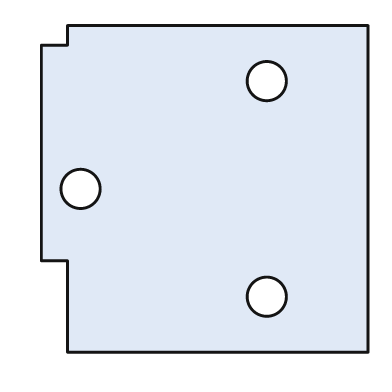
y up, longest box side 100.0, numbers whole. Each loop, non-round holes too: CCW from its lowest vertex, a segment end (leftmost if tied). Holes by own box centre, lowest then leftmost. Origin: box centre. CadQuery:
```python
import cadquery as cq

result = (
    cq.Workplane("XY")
    .moveTo(-42.0, -50.0)
    .lineTo(50.0, -50.0)
    .lineTo(50.0, 50.0)
    .lineTo(-42.0, 50.0)
    .lineTo(-42.0, 44.0)
    .lineTo(-50.0, 44.0)
    .lineTo(-50.0, -22.0)
    .lineTo(-42.0, -22.0)
    .close()
    .moveTo(19.0, -33.0)
    .circle(6.0)
    .moveTo(-38.0, 0.0)
    .circle(6.0)
    .moveTo(19.0, 33.0)
    .circle(6.0)
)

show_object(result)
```